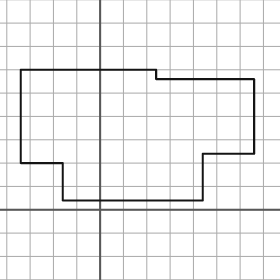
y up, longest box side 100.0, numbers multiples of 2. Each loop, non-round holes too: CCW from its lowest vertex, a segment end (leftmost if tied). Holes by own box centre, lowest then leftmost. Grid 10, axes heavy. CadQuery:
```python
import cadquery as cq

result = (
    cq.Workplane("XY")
    .moveTo(-16.0, 4.0)
    .lineTo(44.0, 4.0)
    .lineTo(44.0, 24.0)
    .lineTo(66.0, 24.0)
    .lineTo(66.0, 56.0)
    .lineTo(24.0, 56.0)
    .lineTo(24.0, 60.0)
    .lineTo(-34.0, 60.0)
    .lineTo(-34.0, 20.0)
    .lineTo(-16.0, 20.0)
    .close()
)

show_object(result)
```